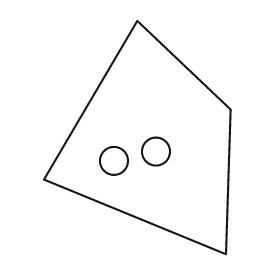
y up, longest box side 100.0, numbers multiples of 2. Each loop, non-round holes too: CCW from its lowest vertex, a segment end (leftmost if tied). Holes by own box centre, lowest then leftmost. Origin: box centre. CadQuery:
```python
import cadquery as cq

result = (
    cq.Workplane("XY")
    .moveTo(38.0, -50.0)
    .lineTo(40.0, 12.0)
    .lineTo(0.0, 50.0)
    .lineTo(-40.0, -18.0)
    .close()
    .moveTo(-10.0, -10.0)
    .circle(6.0)
    .moveTo(8.0, -6.0)
    .circle(6.0)
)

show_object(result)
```